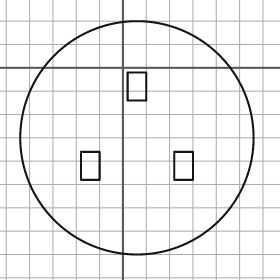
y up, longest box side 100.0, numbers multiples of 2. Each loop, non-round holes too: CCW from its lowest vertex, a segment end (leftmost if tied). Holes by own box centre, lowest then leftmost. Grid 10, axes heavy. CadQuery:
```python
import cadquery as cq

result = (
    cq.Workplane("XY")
    .moveTo(6.0, -30.0)
    .circle(50.0)
    .moveTo(-18.0, -48.0)
    .lineTo(-10.0, -48.0)
    .lineTo(-10.0, -36.0)
    .lineTo(-18.0, -36.0)
    .close()
    .moveTo(22.0, -48.0)
    .lineTo(30.0, -48.0)
    .lineTo(30.0, -36.0)
    .lineTo(22.0, -36.0)
    .close()
    .moveTo(2.0, -14.0)
    .lineTo(10.0, -14.0)
    .lineTo(10.0, -2.0)
    .lineTo(2.0, -2.0)
    .close()
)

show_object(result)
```